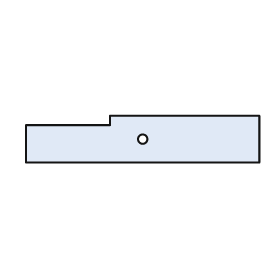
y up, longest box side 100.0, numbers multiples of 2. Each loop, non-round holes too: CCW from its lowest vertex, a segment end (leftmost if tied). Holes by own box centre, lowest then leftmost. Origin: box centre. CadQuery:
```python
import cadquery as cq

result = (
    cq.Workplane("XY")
    .moveTo(-50.0, -10.0)
    .lineTo(50.0, -10.0)
    .lineTo(50.0, 10.0)
    .lineTo(-14.0, 10.0)
    .lineTo(-14.0, 6.0)
    .lineTo(-50.0, 6.0)
    .close()
    .moveTo(0.0, 0.0)
    .circle(2.0)
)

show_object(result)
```